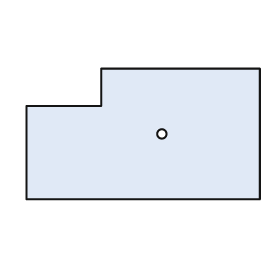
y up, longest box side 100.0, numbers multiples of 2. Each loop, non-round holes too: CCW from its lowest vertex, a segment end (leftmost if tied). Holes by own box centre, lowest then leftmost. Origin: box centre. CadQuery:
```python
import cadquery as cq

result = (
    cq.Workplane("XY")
    .moveTo(-50.0, -28.0)
    .lineTo(50.0, -28.0)
    .lineTo(50.0, 28.0)
    .lineTo(-18.0, 28.0)
    .lineTo(-18.0, 12.0)
    .lineTo(-50.0, 12.0)
    .close()
    .moveTo(8.0, 0.0)
    .circle(2.0)
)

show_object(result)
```